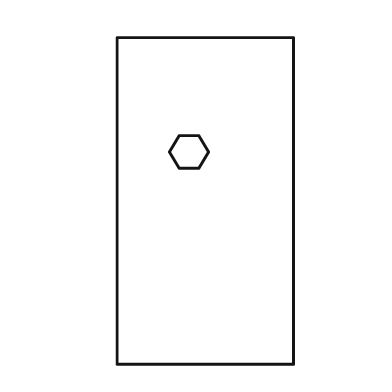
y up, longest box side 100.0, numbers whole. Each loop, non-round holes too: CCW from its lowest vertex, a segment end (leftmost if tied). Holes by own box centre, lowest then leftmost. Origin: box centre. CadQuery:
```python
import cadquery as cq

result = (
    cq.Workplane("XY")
    .moveTo(-27.0, -50.0)
    .lineTo(27.0, -50.0)
    .lineTo(27.0, 50.0)
    .lineTo(-27.0, 50.0)
    .close()
    .moveTo(-8.0, 10.0)
    .lineTo(-2.0, 10.0)
    .lineTo(1.0, 15.0)
    .lineTo(-2.0, 20.0)
    .lineTo(-8.0, 20.0)
    .lineTo(-11.0, 15.0)
    .close()
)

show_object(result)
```